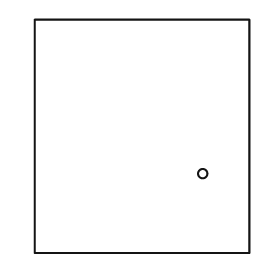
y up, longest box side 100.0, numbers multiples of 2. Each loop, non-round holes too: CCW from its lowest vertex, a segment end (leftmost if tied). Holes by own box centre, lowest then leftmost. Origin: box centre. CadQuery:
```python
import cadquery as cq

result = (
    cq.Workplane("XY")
    .moveTo(-46.0, -50.0)
    .lineTo(46.0, -50.0)
    .lineTo(46.0, 50.0)
    .lineTo(-46.0, 50.0)
    .close()
    .moveTo(26.0, -16.0)
    .circle(2.0)
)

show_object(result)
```